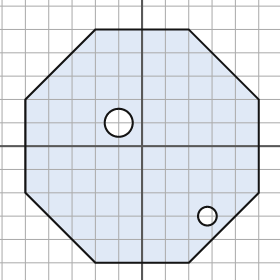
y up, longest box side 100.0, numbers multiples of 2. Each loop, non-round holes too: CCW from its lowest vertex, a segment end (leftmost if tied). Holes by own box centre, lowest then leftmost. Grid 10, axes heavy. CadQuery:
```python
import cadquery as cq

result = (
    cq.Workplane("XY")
    .moveTo(-20.0, -50.0)
    .lineTo(20.0, -50.0)
    .lineTo(50.0, -20.0)
    .lineTo(50.0, 20.0)
    .lineTo(20.0, 50.0)
    .lineTo(-20.0, 50.0)
    .lineTo(-50.0, 20.0)
    .lineTo(-50.0, -20.0)
    .close()
    .moveTo(28.0, -30.0)
    .circle(4.0)
    .moveTo(-10.0, 10.0)
    .circle(6.0)
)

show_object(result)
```